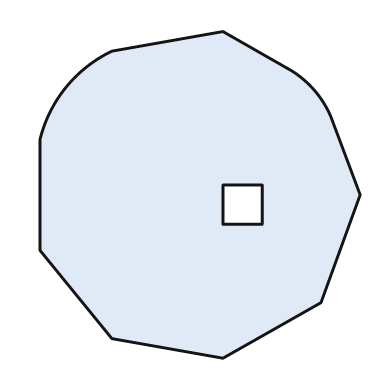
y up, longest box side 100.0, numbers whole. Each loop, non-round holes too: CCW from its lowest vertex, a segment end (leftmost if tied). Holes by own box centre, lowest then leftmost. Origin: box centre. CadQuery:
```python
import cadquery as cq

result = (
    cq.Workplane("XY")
    .moveTo(7.0, -50.0)
    .lineTo(37.0, -33.0)
    .lineTo(49.0, 0.0)
    .lineTo(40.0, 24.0)
    .threePointArc((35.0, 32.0), (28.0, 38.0))
    .lineTo(7.0, 50.0)
    .lineTo(-27.0, 44.0)
    .threePointArc((-41.0, 33.0), (-49.0, 17.0))
    .lineTo(-49.0, -17.0)
    .lineTo(-27.0, -44.0)
    .close()
    .moveTo(7.0, -9.0)
    .lineTo(19.0, -9.0)
    .lineTo(19.0, 3.0)
    .lineTo(7.0, 3.0)
    .close()
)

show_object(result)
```